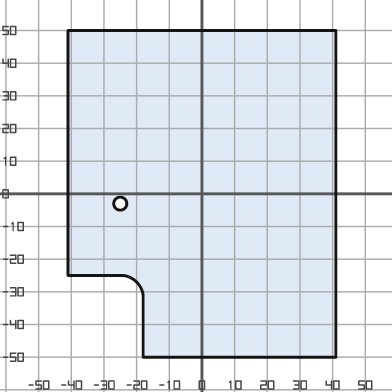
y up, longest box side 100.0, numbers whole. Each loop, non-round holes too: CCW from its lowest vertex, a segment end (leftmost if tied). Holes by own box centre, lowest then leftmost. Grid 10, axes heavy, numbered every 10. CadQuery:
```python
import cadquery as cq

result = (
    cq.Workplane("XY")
    .moveTo(-18.0, -50.0)
    .lineTo(41.0, -50.0)
    .lineTo(41.0, 50.0)
    .lineTo(-41.0, 50.0)
    .lineTo(-41.0, -25.0)
    .lineTo(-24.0, -25.0)
    .threePointArc((-20.0, -27.0), (-18.0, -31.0))
    .close()
    .moveTo(-25.0, -3.0)
    .circle(2.0)
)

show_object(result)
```